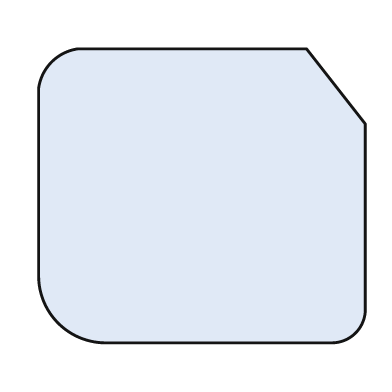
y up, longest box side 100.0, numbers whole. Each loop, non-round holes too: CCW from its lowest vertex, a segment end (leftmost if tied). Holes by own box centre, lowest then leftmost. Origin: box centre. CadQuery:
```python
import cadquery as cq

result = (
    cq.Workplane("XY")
    .moveTo(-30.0, -45.0)
    .lineTo(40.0, -45.0)
    .threePointArc((47.0, -42.0), (50.0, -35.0))
    .lineTo(50.0, 22.0)
    .lineTo(32.0, 45.0)
    .lineTo(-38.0, 45.0)
    .threePointArc((-46.0, 41.0), (-50.0, 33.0))
    .lineTo(-50.0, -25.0)
    .threePointArc((-44.0, -39.0), (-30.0, -45.0))
    .close()
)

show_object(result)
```